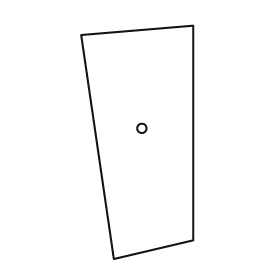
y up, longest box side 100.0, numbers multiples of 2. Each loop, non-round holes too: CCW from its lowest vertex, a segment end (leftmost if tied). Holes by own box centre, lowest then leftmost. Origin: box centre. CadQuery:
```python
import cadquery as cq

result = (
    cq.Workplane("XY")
    .moveTo(-10.0, -50.0)
    .lineTo(24.0, -42.0)
    .lineTo(24.0, 50.0)
    .lineTo(-24.0, 46.0)
    .close()
    .moveTo(2.0, 6.0)
    .circle(2.0)
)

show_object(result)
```